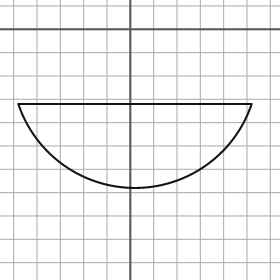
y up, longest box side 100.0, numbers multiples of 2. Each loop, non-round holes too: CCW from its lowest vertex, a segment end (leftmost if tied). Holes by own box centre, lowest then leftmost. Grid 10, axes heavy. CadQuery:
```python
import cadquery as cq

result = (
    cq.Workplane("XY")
    .moveTo(-48.0, -32.0)
    .threePointArc((2.0, -68.0), (52.0, -32.0))
    .close()
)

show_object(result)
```